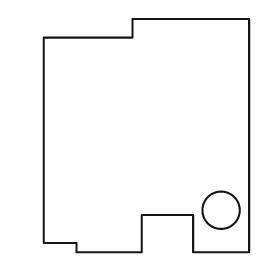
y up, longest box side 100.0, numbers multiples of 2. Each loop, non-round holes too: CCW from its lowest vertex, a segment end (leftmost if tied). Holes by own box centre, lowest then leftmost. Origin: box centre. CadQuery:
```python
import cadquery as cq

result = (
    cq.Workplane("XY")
    .moveTo(-30.0, -50.0)
    .lineTo(-2.0, -50.0)
    .lineTo(-2.0, -34.0)
    .lineTo(20.0, -34.0)
    .lineTo(20.0, -50.0)
    .lineTo(44.0, -50.0)
    .lineTo(44.0, 50.0)
    .lineTo(-6.0, 50.0)
    .lineTo(-6.0, 42.0)
    .lineTo(-44.0, 42.0)
    .lineTo(-44.0, -46.0)
    .lineTo(-30.0, -46.0)
    .close()
    .moveTo(32.0, -32.0)
    .circle(8.0)
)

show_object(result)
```